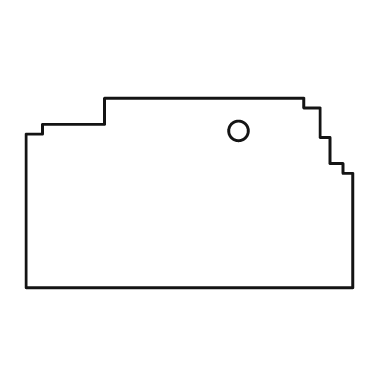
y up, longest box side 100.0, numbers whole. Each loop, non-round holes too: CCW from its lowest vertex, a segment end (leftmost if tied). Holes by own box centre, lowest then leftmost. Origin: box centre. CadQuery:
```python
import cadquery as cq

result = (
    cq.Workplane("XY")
    .moveTo(-50.0, -29.0)
    .lineTo(50.0, -29.0)
    .lineTo(50.0, 6.0)
    .lineTo(47.0, 6.0)
    .lineTo(47.0, 9.0)
    .lineTo(43.0, 9.0)
    .lineTo(43.0, 17.0)
    .lineTo(40.0, 17.0)
    .lineTo(40.0, 26.0)
    .lineTo(35.0, 26.0)
    .lineTo(35.0, 29.0)
    .lineTo(-26.0, 29.0)
    .lineTo(-26.0, 21.0)
    .lineTo(-45.0, 21.0)
    .lineTo(-45.0, 18.0)
    .lineTo(-50.0, 18.0)
    .close()
    .moveTo(15.0, 19.0)
    .circle(3.0)
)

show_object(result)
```